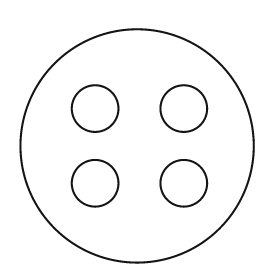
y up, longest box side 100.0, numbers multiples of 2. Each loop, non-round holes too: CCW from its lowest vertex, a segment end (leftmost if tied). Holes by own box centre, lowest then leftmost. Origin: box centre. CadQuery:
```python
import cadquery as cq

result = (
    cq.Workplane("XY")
    .moveTo(0.0, 0.0)
    .circle(50.0)
    .moveTo(-18.0, -16.0)
    .circle(10.0)
    .moveTo(20.0, -16.0)
    .circle(10.0)
    .moveTo(-18.0, 16.0)
    .circle(10.0)
    .moveTo(20.0, 16.0)
    .circle(10.0)
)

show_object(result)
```